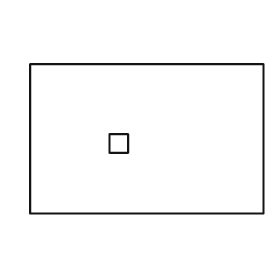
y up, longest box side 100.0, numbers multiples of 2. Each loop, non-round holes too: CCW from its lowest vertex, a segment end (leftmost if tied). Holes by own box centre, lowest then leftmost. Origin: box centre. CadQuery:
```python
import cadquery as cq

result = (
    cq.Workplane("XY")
    .moveTo(-50.0, -32.0)
    .lineTo(50.0, -32.0)
    .lineTo(50.0, 32.0)
    .lineTo(-50.0, 32.0)
    .close()
    .moveTo(-16.0, -6.0)
    .lineTo(-8.0, -6.0)
    .lineTo(-8.0, 2.0)
    .lineTo(-16.0, 2.0)
    .close()
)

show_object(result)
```